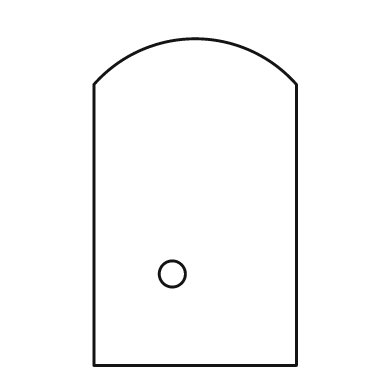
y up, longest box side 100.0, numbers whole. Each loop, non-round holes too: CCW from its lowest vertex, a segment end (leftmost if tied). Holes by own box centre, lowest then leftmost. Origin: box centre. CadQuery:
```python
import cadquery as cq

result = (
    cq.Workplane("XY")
    .moveTo(-31.0, -50.0)
    .lineTo(31.0, -50.0)
    .lineTo(31.0, 36.0)
    .threePointArc((0.0, 50.0), (-31.0, 36.0))
    .close()
    .moveTo(-7.0, -22.0)
    .circle(4.0)
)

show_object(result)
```